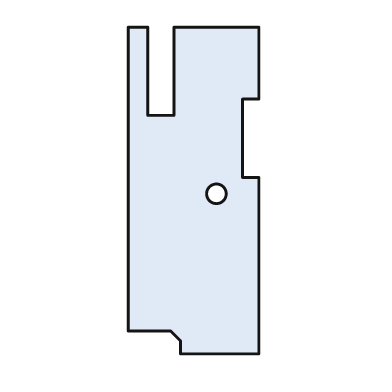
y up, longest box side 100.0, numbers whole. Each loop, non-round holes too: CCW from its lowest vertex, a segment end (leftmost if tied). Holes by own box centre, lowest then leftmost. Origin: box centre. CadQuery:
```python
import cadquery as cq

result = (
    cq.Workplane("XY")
    .moveTo(-4.0, -50.0)
    .lineTo(20.0, -50.0)
    .lineTo(20.0, 4.0)
    .lineTo(15.0, 4.0)
    .lineTo(15.0, 28.0)
    .lineTo(20.0, 28.0)
    .lineTo(20.0, 50.0)
    .lineTo(-6.0, 50.0)
    .lineTo(-6.0, 23.0)
    .lineTo(-14.0, 23.0)
    .lineTo(-14.0, 50.0)
    .lineTo(-20.0, 50.0)
    .lineTo(-20.0, -43.0)
    .lineTo(-7.0, -43.0)
    .lineTo(-4.0, -46.0)
    .close()
    .moveTo(7.0, -1.0)
    .circle(3.0)
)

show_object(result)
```